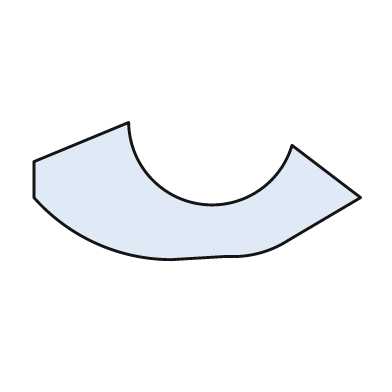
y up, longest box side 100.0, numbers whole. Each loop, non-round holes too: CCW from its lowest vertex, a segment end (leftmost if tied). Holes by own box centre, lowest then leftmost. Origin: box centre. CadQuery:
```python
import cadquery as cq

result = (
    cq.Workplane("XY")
    .moveTo(-8.0, -21.0)
    .lineTo(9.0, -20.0)
    .threePointArc((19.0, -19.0), (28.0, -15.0))
    .lineTo(50.0, -2.0)
    .lineTo(29.0, 14.0)
    .threePointArc((1.0, -4.0), (-21.0, 21.0))
    .lineTo(-50.0, 9.0)
    .lineTo(-50.0, -2.0)
    .threePointArc((-31.0, -16.0), (-8.0, -21.0))
    .close()
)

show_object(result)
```